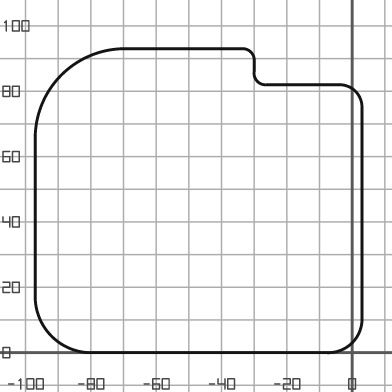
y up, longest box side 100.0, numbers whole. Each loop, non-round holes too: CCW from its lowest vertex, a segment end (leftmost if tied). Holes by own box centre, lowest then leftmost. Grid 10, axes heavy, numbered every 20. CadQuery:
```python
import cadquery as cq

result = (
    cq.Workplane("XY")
    .moveTo(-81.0, 0.0)
    .lineTo(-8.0, 0.0)
    .threePointArc((0.0, 3.0), (3.0, 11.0))
    .lineTo(3.0, 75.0)
    .threePointArc((1.0, 80.0), (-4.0, 82.0))
    .lineTo(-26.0, 82.0)
    .threePointArc((-29.0, 83.0), (-30.0, 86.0))
    .lineTo(-30.0, 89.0)
    .threePointArc((-31.0, 92.0), (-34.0, 93.0))
    .lineTo(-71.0, 93.0)
    .threePointArc((-89.0, 85.0), (-97.0, 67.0))
    .lineTo(-97.0, 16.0)
    .threePointArc((-92.0, 5.0), (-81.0, 0.0))
    .close()
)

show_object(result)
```